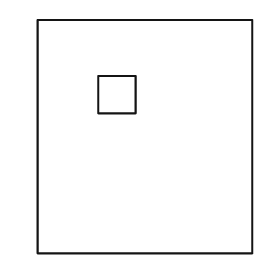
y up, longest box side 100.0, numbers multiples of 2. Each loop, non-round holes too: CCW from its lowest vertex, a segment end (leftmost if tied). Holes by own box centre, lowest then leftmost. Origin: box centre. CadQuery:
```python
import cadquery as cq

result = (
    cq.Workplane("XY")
    .moveTo(-46.0, -50.0)
    .lineTo(46.0, -50.0)
    .lineTo(46.0, 50.0)
    .lineTo(-46.0, 50.0)
    .close()
    .moveTo(-20.0, 10.0)
    .lineTo(-4.0, 10.0)
    .lineTo(-4.0, 26.0)
    .lineTo(-20.0, 26.0)
    .close()
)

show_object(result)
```